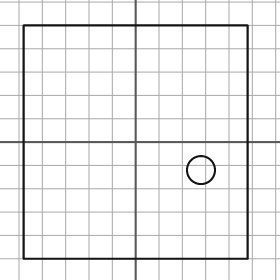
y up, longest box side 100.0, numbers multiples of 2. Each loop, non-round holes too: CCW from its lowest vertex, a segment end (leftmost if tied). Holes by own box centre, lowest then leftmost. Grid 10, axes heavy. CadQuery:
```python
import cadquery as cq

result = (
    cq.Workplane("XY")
    .moveTo(-48.0, -50.0)
    .lineTo(48.0, -50.0)
    .lineTo(48.0, 50.0)
    .lineTo(-48.0, 50.0)
    .close()
    .moveTo(28.0, -12.0)
    .circle(6.0)
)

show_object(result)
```